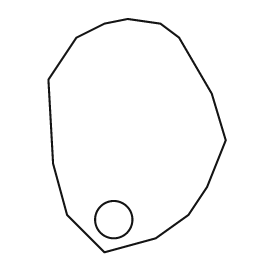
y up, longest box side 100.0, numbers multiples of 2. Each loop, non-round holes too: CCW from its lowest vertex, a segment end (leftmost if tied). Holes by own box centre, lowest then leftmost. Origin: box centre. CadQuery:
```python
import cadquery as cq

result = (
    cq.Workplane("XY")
    .moveTo(-14.0, -50.0)
    .lineTo(8.0, -44.0)
    .lineTo(22.0, -34.0)
    .lineTo(30.0, -22.0)
    .lineTo(38.0, -2.0)
    .lineTo(32.0, 18.0)
    .lineTo(18.0, 42.0)
    .lineTo(10.0, 48.0)
    .lineTo(-4.0, 50.0)
    .lineTo(-14.0, 48.0)
    .lineTo(-26.0, 42.0)
    .lineTo(-38.0, 24.0)
    .lineTo(-36.0, -12.0)
    .lineTo(-30.0, -34.0)
    .close()
    .moveTo(-10.0, -36.0)
    .circle(8.0)
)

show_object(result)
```